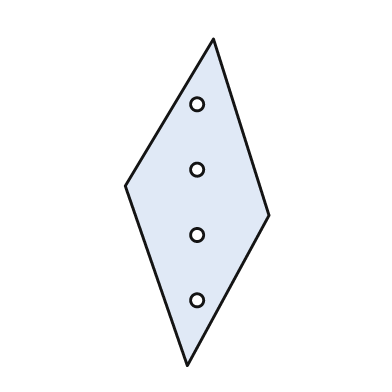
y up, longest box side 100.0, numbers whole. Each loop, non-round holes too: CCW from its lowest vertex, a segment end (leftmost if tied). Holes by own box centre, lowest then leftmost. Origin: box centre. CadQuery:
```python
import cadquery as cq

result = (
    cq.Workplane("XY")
    .moveTo(-3.0, -50.0)
    .lineTo(22.0, -4.0)
    .lineTo(5.0, 50.0)
    .lineTo(-22.0, 5.0)
    .close()
    .moveTo(0.0, -30.0)
    .circle(2.0)
    .moveTo(0.0, -10.0)
    .circle(2.0)
    .moveTo(0.0, 10.0)
    .circle(2.0)
    .moveTo(0.0, 30.0)
    .circle(2.0)
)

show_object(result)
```